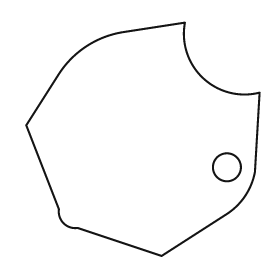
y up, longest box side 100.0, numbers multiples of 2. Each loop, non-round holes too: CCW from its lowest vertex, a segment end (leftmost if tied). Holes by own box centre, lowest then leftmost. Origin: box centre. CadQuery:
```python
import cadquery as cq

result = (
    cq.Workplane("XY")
    .moveTo(8.0, -50.0)
    .lineTo(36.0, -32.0)
    .threePointArc((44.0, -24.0), (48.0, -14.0))
    .lineTo(50.0, 20.0)
    .threePointArc((26.0, 26.0), (18.0, 50.0))
    .lineTo(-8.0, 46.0)
    .threePointArc((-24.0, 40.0), (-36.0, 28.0))
    .lineTo(-50.0, 6.0)
    .lineTo(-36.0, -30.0)
    .threePointArc((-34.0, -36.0), (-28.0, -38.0))
    .close()
    .moveTo(36.0, -12.0)
    .circle(6.0)
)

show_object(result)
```